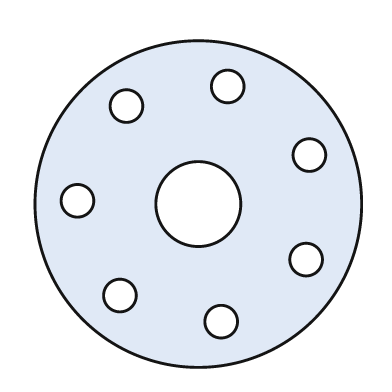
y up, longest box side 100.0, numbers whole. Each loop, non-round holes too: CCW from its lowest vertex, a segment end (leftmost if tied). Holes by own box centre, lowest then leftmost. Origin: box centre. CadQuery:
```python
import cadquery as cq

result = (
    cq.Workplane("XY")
    .moveTo(0.0, 0.0)
    .circle(50.0)
    .moveTo(7.0, -36.0)
    .circle(5.0)
    .moveTo(-24.0, -28.0)
    .circle(5.0)
    .moveTo(33.0, -17.0)
    .circle(5.0)
    .moveTo(0.0, 0.0)
    .circle(13.0)
    .moveTo(-37.0, 1.0)
    .circle(5.0)
    .moveTo(34.0, 15.0)
    .circle(5.0)
    .moveTo(-22.0, 30.0)
    .circle(5.0)
    .moveTo(9.0, 36.0)
    .circle(5.0)
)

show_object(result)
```